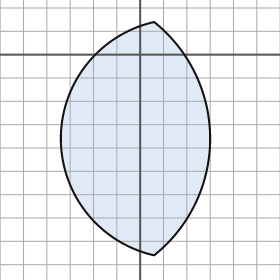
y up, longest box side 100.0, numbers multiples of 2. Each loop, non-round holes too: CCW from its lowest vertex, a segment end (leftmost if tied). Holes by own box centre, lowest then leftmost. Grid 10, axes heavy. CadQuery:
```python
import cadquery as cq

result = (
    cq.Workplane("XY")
    .moveTo(6.0, -86.0)
    .threePointArc((30.0, -36.0), (6.0, 14.0))
    .threePointArc((-34.0, -36.0), (6.0, -86.0))
    .close()
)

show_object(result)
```